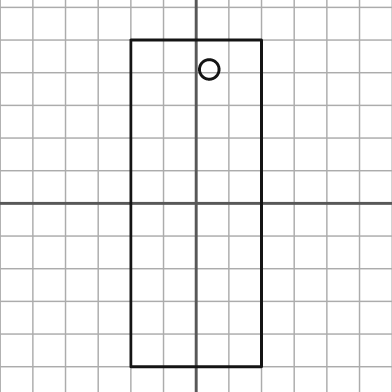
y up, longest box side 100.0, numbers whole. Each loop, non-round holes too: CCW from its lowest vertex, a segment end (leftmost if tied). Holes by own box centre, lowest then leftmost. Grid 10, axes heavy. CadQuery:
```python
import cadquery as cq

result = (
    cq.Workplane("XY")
    .moveTo(-20.0, -50.0)
    .lineTo(20.0, -50.0)
    .lineTo(20.0, 50.0)
    .lineTo(-20.0, 50.0)
    .close()
    .moveTo(4.0, 41.0)
    .circle(3.0)
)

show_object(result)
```